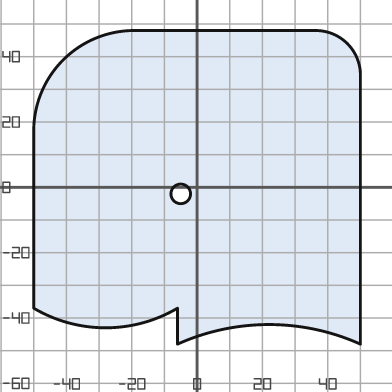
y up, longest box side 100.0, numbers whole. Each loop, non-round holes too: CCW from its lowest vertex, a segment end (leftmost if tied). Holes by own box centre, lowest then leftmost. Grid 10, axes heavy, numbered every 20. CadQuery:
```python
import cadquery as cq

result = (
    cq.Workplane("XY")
    .moveTo(-6.0, -48.0)
    .threePointArc((22.0, -42.0), (50.0, -48.0))
    .lineTo(50.0, 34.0)
    .threePointArc((46.0, 44.0), (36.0, 48.0))
    .lineTo(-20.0, 48.0)
    .threePointArc((-41.0, 39.0), (-50.0, 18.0))
    .lineTo(-50.0, -37.0)
    .threePointArc((-28.0, -43.0), (-6.0, -37.0))
    .close()
    .moveTo(-5.0, -2.0)
    .circle(3.0)
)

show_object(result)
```